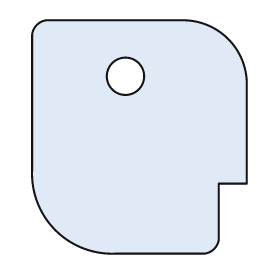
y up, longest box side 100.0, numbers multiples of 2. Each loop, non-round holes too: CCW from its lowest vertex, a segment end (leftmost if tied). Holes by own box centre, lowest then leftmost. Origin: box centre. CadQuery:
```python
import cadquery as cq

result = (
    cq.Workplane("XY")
    .moveTo(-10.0, -50.0)
    .lineTo(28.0, -50.0)
    .threePointArc((32.0, -48.0), (34.0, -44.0))
    .lineTo(34.0, -20.0)
    .lineTo(46.0, -20.0)
    .lineTo(46.0, 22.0)
    .threePointArc((38.0, 42.0), (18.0, 50.0))
    .lineTo(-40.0, 50.0)
    .threePointArc((-44.0, 48.0), (-46.0, 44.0))
    .lineTo(-46.0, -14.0)
    .threePointArc((-36.0, -40.0), (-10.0, -50.0))
    .close()
    .moveTo(-6.0, 26.0)
    .circle(8.0)
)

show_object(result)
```